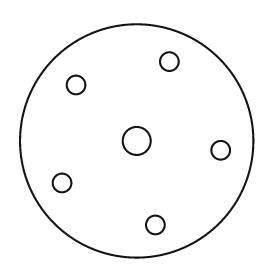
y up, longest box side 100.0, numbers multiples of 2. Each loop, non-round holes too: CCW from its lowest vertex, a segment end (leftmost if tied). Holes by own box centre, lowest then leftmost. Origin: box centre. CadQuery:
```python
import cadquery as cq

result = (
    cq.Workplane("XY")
    .moveTo(0.0, 0.0)
    .circle(50.0)
    .moveTo(8.0, -36.0)
    .circle(4.0)
    .moveTo(-32.0, -18.0)
    .circle(4.0)
    .moveTo(36.0, -4.0)
    .circle(4.0)
    .moveTo(0.0, 0.0)
    .circle(6.0)
    .moveTo(-26.0, 24.0)
    .circle(4.0)
    .moveTo(14.0, 34.0)
    .circle(4.0)
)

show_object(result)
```